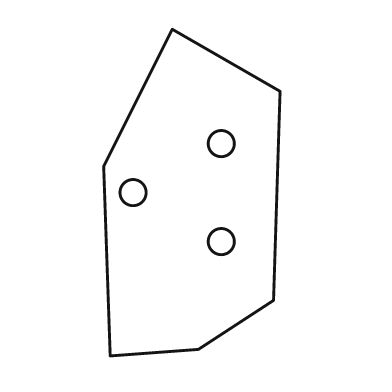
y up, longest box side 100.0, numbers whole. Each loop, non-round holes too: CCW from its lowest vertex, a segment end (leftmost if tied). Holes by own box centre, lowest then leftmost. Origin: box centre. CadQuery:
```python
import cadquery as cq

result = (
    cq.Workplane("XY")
    .moveTo(-25.0, -50.0)
    .lineTo(2.0, -48.0)
    .lineTo(25.0, -33.0)
    .lineTo(27.0, 31.0)
    .lineTo(-6.0, 50.0)
    .lineTo(-27.0, 8.0)
    .close()
    .moveTo(9.0, -15.0)
    .circle(4.0)
    .moveTo(-18.0, 0.0)
    .circle(4.0)
    .moveTo(9.0, 15.0)
    .circle(4.0)
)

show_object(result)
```